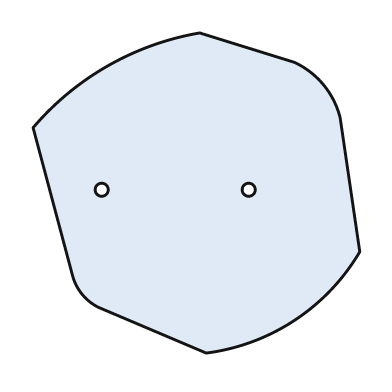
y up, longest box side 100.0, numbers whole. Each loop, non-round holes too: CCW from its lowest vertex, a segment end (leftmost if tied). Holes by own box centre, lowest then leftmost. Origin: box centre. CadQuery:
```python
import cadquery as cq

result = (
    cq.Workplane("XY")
    .moveTo(3.0, -49.0)
    .threePointArc((30.0, -39.0), (50.0, -18.0))
    .lineTo(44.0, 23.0)
    .threePointArc((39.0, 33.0), (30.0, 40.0))
    .lineTo(1.0, 49.0)
    .threePointArc((-27.0, 39.0), (-50.0, 20.0))
    .lineTo(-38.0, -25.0)
    .threePointArc((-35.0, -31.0), (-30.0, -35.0))
    .close()
    .moveTo(-29.0, 1.0)
    .circle(2.0)
    .moveTo(16.0, 1.0)
    .circle(2.0)
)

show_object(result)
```